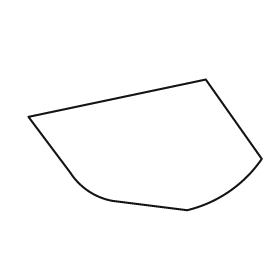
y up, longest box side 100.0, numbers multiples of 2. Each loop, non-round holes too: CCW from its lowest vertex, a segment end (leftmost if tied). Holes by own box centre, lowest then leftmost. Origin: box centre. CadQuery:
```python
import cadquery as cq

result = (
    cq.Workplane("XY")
    .moveTo(18.0, -28.0)
    .threePointArc((36.0, -20.0), (50.0, -6.0))
    .lineTo(26.0, 28.0)
    .lineTo(-50.0, 12.0)
    .lineTo(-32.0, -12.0)
    .threePointArc((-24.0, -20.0), (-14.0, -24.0))
    .close()
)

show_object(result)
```